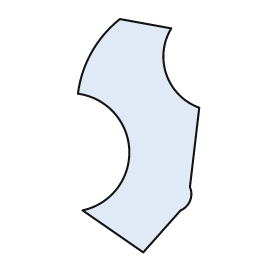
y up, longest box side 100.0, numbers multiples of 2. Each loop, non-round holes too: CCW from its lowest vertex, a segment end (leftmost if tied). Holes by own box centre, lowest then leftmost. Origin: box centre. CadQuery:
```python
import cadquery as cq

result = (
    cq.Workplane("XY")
    .moveTo(2.0, -50.0)
    .lineTo(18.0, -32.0)
    .threePointArc((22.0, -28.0), (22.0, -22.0))
    .lineTo(26.0, 12.0)
    .threePointArc((12.0, 26.0), (14.0, 46.0))
    .lineTo(-8.0, 50.0)
    .threePointArc((-20.0, 36.0), (-26.0, 18.0))
    .threePointArc((-4.0, -6.0), (-24.0, -32.0))
    .close()
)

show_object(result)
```